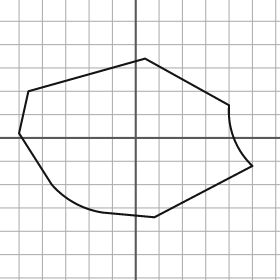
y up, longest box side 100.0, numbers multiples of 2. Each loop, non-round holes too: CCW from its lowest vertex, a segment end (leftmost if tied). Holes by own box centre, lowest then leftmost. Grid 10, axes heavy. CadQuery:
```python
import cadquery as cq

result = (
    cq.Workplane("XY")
    .moveTo(8.0, -34.0)
    .lineTo(50.0, -12.0)
    .threePointArc((42.0, 0.0), (40.0, 14.0))
    .lineTo(4.0, 34.0)
    .lineTo(-46.0, 20.0)
    .lineTo(-50.0, 2.0)
    .lineTo(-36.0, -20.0)
    .threePointArc((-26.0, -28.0), (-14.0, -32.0))
    .close()
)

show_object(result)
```